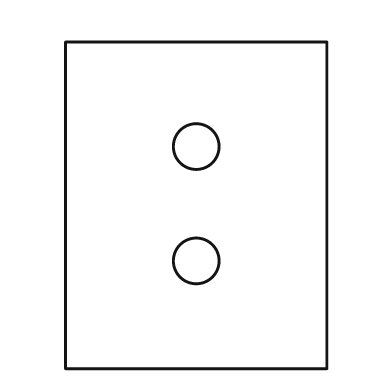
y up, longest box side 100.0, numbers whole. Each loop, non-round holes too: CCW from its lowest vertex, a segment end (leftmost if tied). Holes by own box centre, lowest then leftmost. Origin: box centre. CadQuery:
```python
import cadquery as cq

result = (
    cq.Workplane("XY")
    .moveTo(-40.0, -50.0)
    .lineTo(40.0, -50.0)
    .lineTo(40.0, 50.0)
    .lineTo(-40.0, 50.0)
    .close()
    .moveTo(0.0, -17.0)
    .circle(7.0)
    .moveTo(0.0, 18.0)
    .circle(7.0)
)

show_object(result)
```